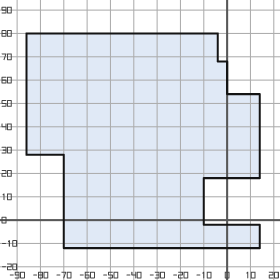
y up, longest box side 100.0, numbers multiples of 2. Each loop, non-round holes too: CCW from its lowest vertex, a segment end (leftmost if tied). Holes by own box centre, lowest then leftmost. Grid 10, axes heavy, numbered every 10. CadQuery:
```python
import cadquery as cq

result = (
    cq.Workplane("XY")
    .moveTo(-70.0, -12.0)
    .lineTo(14.0, -12.0)
    .lineTo(14.0, -2.0)
    .lineTo(-10.0, -2.0)
    .lineTo(-10.0, 18.0)
    .lineTo(14.0, 18.0)
    .lineTo(14.0, 54.0)
    .lineTo(0.0, 54.0)
    .lineTo(0.0, 68.0)
    .lineTo(-4.0, 68.0)
    .lineTo(-4.0, 80.0)
    .lineTo(-86.0, 80.0)
    .lineTo(-86.0, 28.0)
    .lineTo(-70.0, 28.0)
    .close()
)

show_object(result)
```